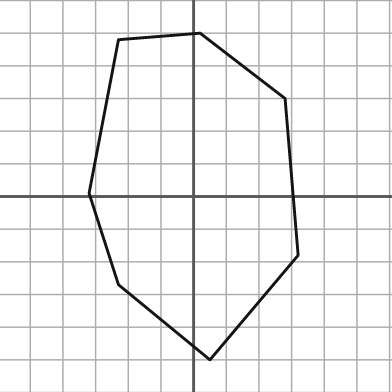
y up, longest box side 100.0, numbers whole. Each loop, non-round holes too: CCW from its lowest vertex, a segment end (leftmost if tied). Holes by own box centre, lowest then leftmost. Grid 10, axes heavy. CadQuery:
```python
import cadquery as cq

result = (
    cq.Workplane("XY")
    .moveTo(5.0, -50.0)
    .lineTo(32.0, -18.0)
    .lineTo(28.0, 30.0)
    .lineTo(2.0, 50.0)
    .lineTo(-23.0, 48.0)
    .lineTo(-32.0, 1.0)
    .lineTo(-23.0, -27.0)
    .close()
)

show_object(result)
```